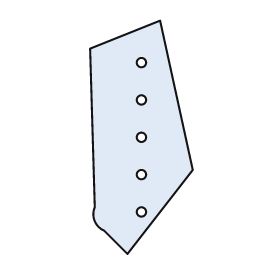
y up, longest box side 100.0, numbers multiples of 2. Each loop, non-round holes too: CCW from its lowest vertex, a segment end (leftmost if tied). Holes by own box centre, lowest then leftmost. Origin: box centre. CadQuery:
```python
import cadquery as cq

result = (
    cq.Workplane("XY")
    .moveTo(-6.0, -50.0)
    .lineTo(22.0, -14.0)
    .lineTo(8.0, 50.0)
    .lineTo(-22.0, 38.0)
    .lineTo(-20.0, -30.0)
    .threePointArc((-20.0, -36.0), (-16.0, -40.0))
    .close()
    .moveTo(0.0, -32.0)
    .circle(2.0)
    .moveTo(0.0, -16.0)
    .circle(2.0)
    .moveTo(0.0, 0.0)
    .circle(2.0)
    .moveTo(0.0, 16.0)
    .circle(2.0)
    .moveTo(0.0, 32.0)
    .circle(2.0)
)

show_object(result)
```